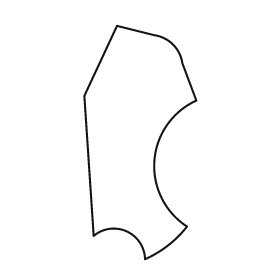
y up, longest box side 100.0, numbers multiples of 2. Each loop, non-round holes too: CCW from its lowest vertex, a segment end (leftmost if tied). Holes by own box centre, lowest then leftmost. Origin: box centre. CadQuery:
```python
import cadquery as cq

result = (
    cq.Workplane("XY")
    .moveTo(2.0, -50.0)
    .threePointArc((12.0, -44.0), (20.0, -36.0))
    .threePointArc((6.0, -8.0), (24.0, 18.0))
    .lineTo(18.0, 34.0)
    .threePointArc((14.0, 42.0), (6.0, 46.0))
    .lineTo(-10.0, 50.0)
    .lineTo(-24.0, 20.0)
    .lineTo(-20.0, -40.0)
    .threePointArc((-6.0, -38.0), (2.0, -50.0))
    .close()
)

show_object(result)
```